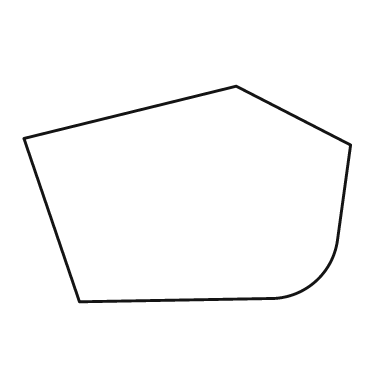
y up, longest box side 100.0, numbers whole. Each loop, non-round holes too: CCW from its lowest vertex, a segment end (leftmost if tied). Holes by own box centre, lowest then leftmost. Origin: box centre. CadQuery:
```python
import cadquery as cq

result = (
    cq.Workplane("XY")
    .moveTo(-33.0, -33.0)
    .lineTo(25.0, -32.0)
    .threePointArc((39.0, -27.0), (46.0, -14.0))
    .lineTo(50.0, 15.0)
    .lineTo(15.0, 33.0)
    .lineTo(-50.0, 17.0)
    .close()
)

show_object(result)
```